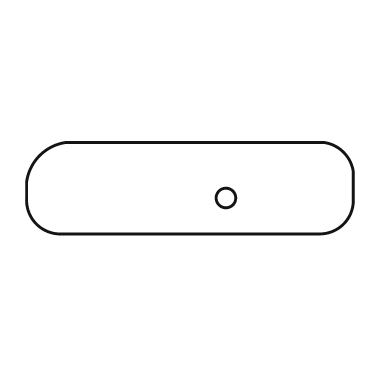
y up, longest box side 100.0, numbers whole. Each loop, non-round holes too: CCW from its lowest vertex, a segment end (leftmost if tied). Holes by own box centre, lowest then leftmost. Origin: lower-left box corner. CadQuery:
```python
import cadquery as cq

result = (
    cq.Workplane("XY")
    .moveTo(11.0, 0.0)
    .lineTo(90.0, 0.0)
    .threePointArc((97.0, 3.0), (100.0, 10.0))
    .lineTo(100.0, 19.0)
    .threePointArc((97.0, 25.0), (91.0, 28.0))
    .lineTo(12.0, 28.0)
    .threePointArc((4.0, 24.0), (0.0, 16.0))
    .lineTo(0.0, 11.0)
    .threePointArc((3.0, 3.0), (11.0, 0.0))
    .close()
    .moveTo(61.0, 11.0)
    .circle(3.0)
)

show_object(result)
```